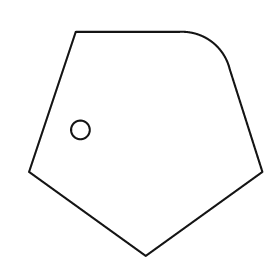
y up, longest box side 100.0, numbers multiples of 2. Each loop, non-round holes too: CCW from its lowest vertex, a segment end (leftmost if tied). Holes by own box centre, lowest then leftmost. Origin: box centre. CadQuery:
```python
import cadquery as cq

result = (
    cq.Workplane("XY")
    .moveTo(0.0, -48.0)
    .lineTo(50.0, -12.0)
    .lineTo(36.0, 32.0)
    .threePointArc((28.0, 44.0), (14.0, 48.0))
    .lineTo(-30.0, 48.0)
    .lineTo(-50.0, -12.0)
    .close()
    .moveTo(-28.0, 6.0)
    .circle(4.0)
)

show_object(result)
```